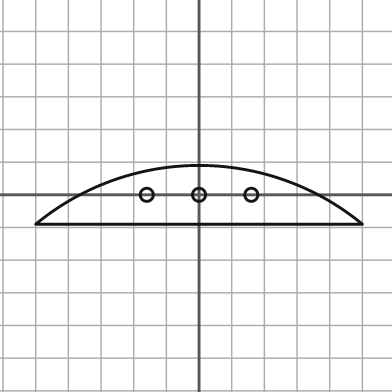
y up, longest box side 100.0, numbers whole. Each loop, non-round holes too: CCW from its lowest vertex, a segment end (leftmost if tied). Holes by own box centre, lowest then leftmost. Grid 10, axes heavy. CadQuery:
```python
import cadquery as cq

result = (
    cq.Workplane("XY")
    .moveTo(-50.0, -9.0)
    .lineTo(50.0, -9.0)
    .threePointArc((0.0, 9.0), (-50.0, -9.0))
    .close()
    .moveTo(-16.0, 0.0)
    .circle(2.0)
    .moveTo(0.0, 0.0)
    .circle(2.0)
    .moveTo(16.0, 0.0)
    .circle(2.0)
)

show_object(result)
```